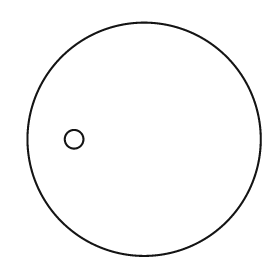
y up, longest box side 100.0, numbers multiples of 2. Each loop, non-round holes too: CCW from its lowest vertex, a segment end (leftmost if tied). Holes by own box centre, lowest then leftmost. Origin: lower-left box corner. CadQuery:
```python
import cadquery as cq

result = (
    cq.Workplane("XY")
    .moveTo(50.0, 50.0)
    .circle(50.0)
    .moveTo(20.0, 50.0)
    .circle(4.0)
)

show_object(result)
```